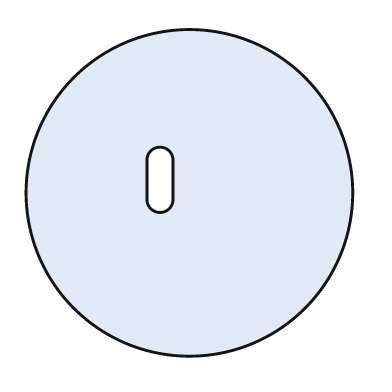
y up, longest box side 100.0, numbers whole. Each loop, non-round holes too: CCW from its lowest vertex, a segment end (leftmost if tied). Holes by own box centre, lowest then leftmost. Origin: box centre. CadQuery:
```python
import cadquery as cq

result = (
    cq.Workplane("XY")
    .moveTo(0.0, 0.0)
    .circle(50.0)
    .moveTo(-13.0, -2.0)
    .threePointArc((-9.0, -6.0), (-5.0, -2.0))
    .lineTo(-5.0, 10.0)
    .threePointArc((-9.0, 14.0), (-13.0, 10.0))
    .close()
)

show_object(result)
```